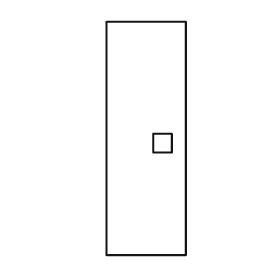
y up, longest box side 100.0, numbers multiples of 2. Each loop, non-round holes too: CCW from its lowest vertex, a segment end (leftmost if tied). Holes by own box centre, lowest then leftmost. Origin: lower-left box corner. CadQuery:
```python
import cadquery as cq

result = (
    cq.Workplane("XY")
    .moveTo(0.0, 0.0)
    .lineTo(34.0, 0.0)
    .lineTo(34.0, 100.0)
    .lineTo(0.0, 100.0)
    .close()
    .moveTo(20.0, 44.0)
    .lineTo(28.0, 44.0)
    .lineTo(28.0, 52.0)
    .lineTo(20.0, 52.0)
    .close()
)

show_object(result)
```